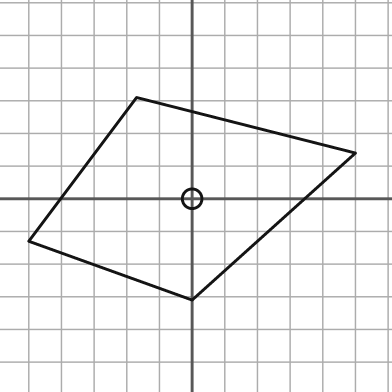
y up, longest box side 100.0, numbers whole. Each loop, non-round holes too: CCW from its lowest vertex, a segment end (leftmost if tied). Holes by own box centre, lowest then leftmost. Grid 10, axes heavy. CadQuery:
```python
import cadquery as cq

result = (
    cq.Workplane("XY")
    .moveTo(0.0, -31.0)
    .lineTo(50.0, 14.0)
    .lineTo(-17.0, 31.0)
    .lineTo(-50.0, -13.0)
    .close()
    .moveTo(0.0, 0.0)
    .circle(3.0)
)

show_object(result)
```